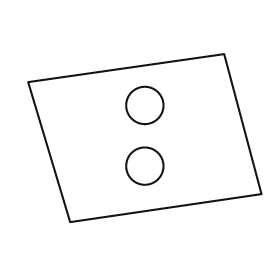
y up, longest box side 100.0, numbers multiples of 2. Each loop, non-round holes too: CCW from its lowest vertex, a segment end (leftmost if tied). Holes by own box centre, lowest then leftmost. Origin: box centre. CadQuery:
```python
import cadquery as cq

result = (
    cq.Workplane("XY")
    .moveTo(-32.0, -36.0)
    .lineTo(50.0, -24.0)
    .lineTo(34.0, 36.0)
    .lineTo(-50.0, 24.0)
    .close()
    .moveTo(0.0, -12.0)
    .circle(8.0)
    .moveTo(0.0, 14.0)
    .circle(8.0)
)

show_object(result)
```